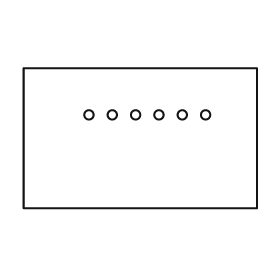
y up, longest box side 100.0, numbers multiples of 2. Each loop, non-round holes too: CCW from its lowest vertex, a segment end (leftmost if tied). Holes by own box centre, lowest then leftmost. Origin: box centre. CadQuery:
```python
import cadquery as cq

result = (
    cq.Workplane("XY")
    .moveTo(-50.0, -30.0)
    .lineTo(50.0, -30.0)
    .lineTo(50.0, 30.0)
    .lineTo(-50.0, 30.0)
    .close()
    .moveTo(-22.0, 10.0)
    .circle(2.0)
    .moveTo(-12.0, 10.0)
    .circle(2.0)
    .moveTo(-2.0, 10.0)
    .circle(2.0)
    .moveTo(8.0, 10.0)
    .circle(2.0)
    .moveTo(18.0, 10.0)
    .circle(2.0)
    .moveTo(28.0, 10.0)
    .circle(2.0)
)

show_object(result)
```